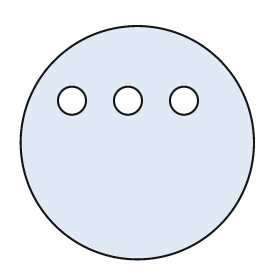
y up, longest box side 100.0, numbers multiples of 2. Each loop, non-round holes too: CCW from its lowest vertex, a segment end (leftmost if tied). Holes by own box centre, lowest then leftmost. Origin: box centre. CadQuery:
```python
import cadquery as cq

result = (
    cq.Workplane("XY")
    .moveTo(0.0, 0.0)
    .circle(50.0)
    .moveTo(-28.0, 18.0)
    .circle(6.0)
    .moveTo(-4.0, 18.0)
    .circle(6.0)
    .moveTo(20.0, 18.0)
    .circle(6.0)
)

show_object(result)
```